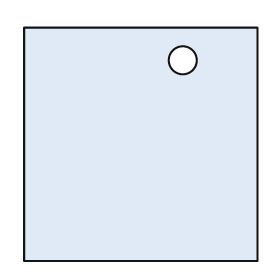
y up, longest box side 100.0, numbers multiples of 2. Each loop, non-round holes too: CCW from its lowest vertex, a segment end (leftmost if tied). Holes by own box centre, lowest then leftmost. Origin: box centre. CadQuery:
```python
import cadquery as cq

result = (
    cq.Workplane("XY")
    .moveTo(-50.0, -50.0)
    .lineTo(50.0, -50.0)
    .lineTo(50.0, 50.0)
    .lineTo(-50.0, 50.0)
    .close()
    .moveTo(18.0, 36.0)
    .circle(6.0)
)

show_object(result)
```